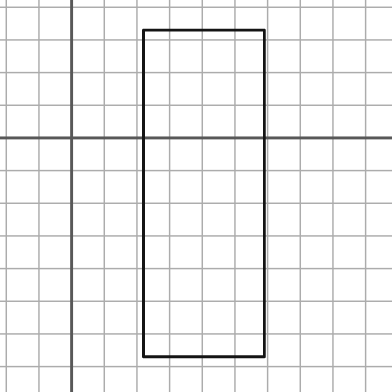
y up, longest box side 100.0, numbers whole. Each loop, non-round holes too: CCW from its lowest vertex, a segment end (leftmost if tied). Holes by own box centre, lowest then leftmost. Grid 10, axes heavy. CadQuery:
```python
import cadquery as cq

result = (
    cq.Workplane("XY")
    .moveTo(22.0, -67.0)
    .lineTo(59.0, -67.0)
    .lineTo(59.0, 33.0)
    .lineTo(22.0, 33.0)
    .close()
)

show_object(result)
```